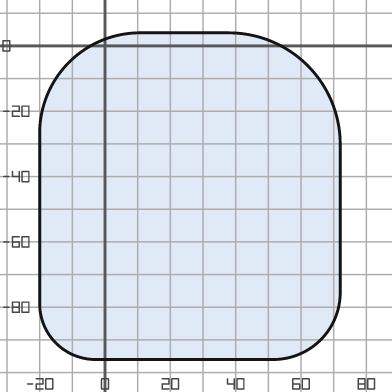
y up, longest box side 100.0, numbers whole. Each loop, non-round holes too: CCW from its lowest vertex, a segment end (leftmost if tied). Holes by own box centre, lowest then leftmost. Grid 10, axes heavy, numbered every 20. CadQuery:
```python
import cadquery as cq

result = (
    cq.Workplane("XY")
    .moveTo(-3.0, -96.0)
    .lineTo(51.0, -96.0)
    .threePointArc((66.0, -90.0), (72.0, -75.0))
    .lineTo(72.0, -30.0)
    .threePointArc((62.0, -6.0), (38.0, 4.0))
    .lineTo(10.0, 4.0)
    .threePointArc((-11.0, -5.0), (-20.0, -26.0))
    .lineTo(-20.0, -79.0)
    .threePointArc((-15.0, -91.0), (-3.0, -96.0))
    .close()
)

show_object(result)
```